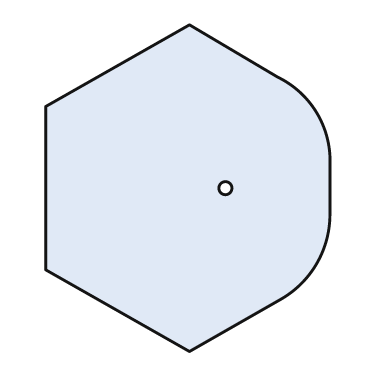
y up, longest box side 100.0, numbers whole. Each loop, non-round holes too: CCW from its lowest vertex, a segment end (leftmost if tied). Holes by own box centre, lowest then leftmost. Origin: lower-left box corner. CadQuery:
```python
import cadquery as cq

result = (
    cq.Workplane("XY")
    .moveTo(44.0, 0.0)
    .lineTo(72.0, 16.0)
    .threePointArc((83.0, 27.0), (87.0, 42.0))
    .lineTo(87.0, 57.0)
    .threePointArc((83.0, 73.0), (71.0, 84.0))
    .lineTo(44.0, 100.0)
    .lineTo(0.0, 75.0)
    .lineTo(0.0, 25.0)
    .close()
    .moveTo(55.0, 50.0)
    .circle(2.0)
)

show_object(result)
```